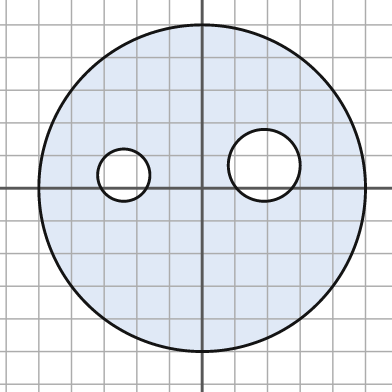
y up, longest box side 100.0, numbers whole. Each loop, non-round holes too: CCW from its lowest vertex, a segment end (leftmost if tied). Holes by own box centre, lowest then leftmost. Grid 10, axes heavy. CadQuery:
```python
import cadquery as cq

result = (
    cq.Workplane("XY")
    .moveTo(0.0, 0.0)
    .circle(50.0)
    .moveTo(-24.0, 4.0)
    .circle(8.0)
    .moveTo(19.0, 7.0)
    .circle(11.0)
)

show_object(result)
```